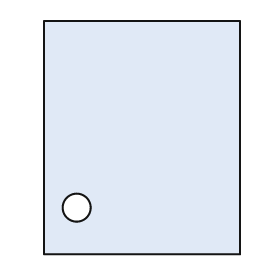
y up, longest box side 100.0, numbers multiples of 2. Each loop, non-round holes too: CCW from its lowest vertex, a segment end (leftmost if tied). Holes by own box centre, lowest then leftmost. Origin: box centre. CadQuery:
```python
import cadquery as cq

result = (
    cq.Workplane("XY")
    .moveTo(-42.0, -50.0)
    .lineTo(42.0, -50.0)
    .lineTo(42.0, 50.0)
    .lineTo(-42.0, 50.0)
    .close()
    .moveTo(-28.0, -30.0)
    .circle(6.0)
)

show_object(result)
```